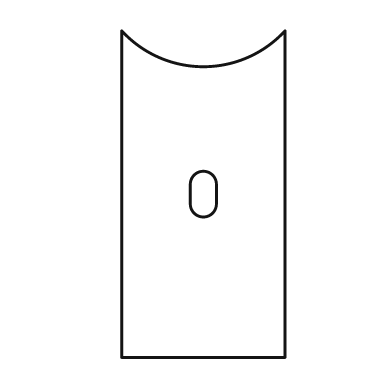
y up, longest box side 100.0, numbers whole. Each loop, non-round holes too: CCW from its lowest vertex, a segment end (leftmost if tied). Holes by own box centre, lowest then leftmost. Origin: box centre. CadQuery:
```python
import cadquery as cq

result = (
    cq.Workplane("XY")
    .moveTo(-25.0, -50.0)
    .lineTo(25.0, -50.0)
    .lineTo(25.0, 50.0)
    .threePointArc((0.0, 39.0), (-25.0, 50.0))
    .close()
    .moveTo(-4.0, -3.0)
    .threePointArc((0.0, -7.0), (4.0, -3.0))
    .lineTo(4.0, 3.0)
    .threePointArc((0.0, 7.0), (-4.0, 3.0))
    .close()
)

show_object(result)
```